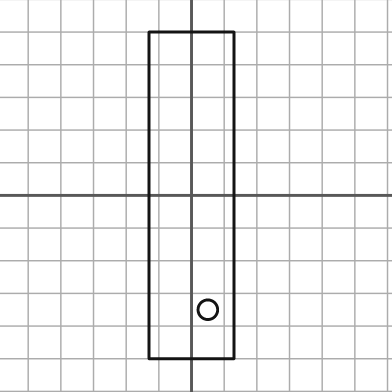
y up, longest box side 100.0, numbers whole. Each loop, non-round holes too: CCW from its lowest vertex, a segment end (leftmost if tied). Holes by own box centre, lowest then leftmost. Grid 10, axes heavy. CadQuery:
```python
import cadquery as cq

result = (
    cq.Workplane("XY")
    .moveTo(-13.0, -50.0)
    .lineTo(13.0, -50.0)
    .lineTo(13.0, 50.0)
    .lineTo(-13.0, 50.0)
    .close()
    .moveTo(5.0, -35.0)
    .circle(3.0)
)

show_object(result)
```